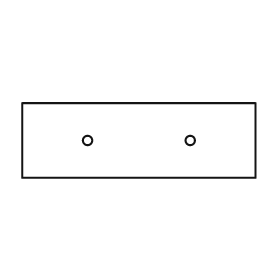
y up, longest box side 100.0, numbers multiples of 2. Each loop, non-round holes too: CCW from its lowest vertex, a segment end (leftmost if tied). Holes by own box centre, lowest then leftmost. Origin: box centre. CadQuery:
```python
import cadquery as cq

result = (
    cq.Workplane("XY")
    .moveTo(-50.0, -16.0)
    .lineTo(50.0, -16.0)
    .lineTo(50.0, 16.0)
    .lineTo(-50.0, 16.0)
    .close()
    .moveTo(-22.0, 0.0)
    .circle(2.0)
    .moveTo(22.0, 0.0)
    .circle(2.0)
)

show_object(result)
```